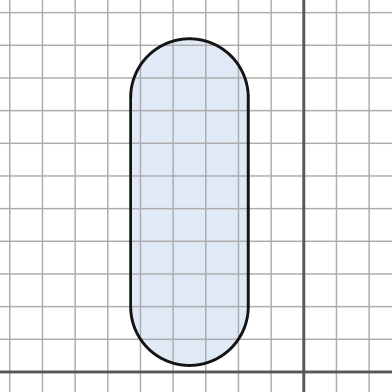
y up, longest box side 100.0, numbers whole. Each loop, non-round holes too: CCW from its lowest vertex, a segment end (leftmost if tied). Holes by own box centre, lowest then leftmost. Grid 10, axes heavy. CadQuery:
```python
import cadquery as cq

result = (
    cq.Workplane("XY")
    .moveTo(-53.0, 20.0)
    .threePointArc((-35.0, 2.0), (-17.0, 20.0))
    .lineTo(-17.0, 84.0)
    .threePointArc((-35.0, 102.0), (-53.0, 84.0))
    .close()
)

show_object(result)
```